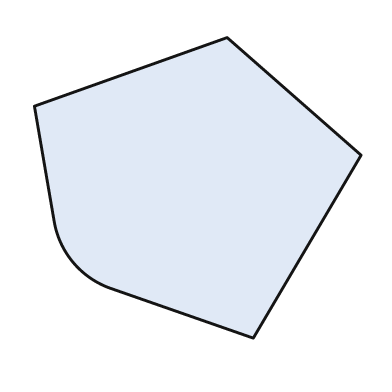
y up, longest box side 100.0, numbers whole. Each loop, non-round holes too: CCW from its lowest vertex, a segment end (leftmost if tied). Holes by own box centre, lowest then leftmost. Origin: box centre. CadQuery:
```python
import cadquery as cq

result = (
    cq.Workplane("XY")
    .moveTo(17.0, -46.0)
    .lineTo(50.0, 10.0)
    .lineTo(9.0, 46.0)
    .lineTo(-50.0, 25.0)
    .lineTo(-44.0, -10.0)
    .threePointArc((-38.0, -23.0), (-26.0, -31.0))
    .close()
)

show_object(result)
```